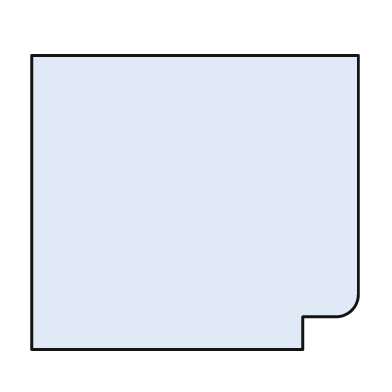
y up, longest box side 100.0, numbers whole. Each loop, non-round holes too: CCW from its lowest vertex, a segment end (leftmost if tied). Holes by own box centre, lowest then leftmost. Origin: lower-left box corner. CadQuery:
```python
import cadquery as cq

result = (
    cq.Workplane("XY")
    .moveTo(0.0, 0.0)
    .lineTo(83.0, 0.0)
    .lineTo(83.0, 10.0)
    .lineTo(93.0, 10.0)
    .threePointArc((98.0, 12.0), (100.0, 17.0))
    .lineTo(100.0, 90.0)
    .lineTo(0.0, 90.0)
    .close()
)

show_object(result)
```